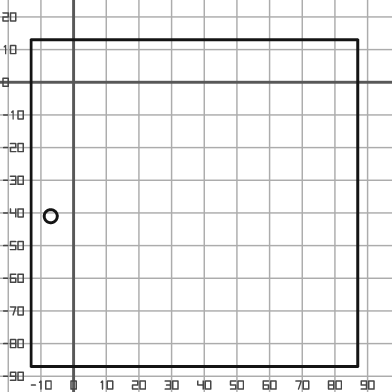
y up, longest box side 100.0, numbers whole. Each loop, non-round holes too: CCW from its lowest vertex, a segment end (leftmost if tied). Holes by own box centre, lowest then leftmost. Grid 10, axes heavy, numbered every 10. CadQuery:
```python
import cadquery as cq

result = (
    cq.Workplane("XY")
    .moveTo(-13.0, -87.0)
    .lineTo(87.0, -87.0)
    .lineTo(87.0, 13.0)
    .lineTo(-13.0, 13.0)
    .close()
    .moveTo(-7.0, -41.0)
    .circle(2.0)
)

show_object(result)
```